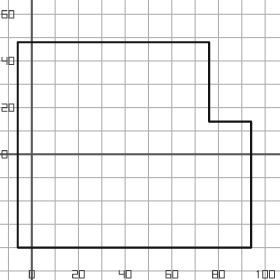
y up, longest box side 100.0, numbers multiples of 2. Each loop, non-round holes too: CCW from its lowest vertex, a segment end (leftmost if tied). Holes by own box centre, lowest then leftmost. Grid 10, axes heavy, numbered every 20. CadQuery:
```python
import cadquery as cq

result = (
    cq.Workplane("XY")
    .moveTo(-6.0, -40.0)
    .lineTo(94.0, -40.0)
    .lineTo(94.0, 14.0)
    .lineTo(76.0, 14.0)
    .lineTo(76.0, 48.0)
    .lineTo(-6.0, 48.0)
    .close()
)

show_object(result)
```